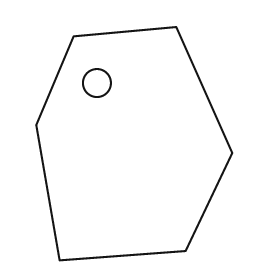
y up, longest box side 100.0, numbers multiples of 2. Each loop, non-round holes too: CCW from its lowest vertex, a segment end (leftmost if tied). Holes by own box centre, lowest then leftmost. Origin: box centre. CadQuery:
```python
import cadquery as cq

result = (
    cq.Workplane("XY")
    .moveTo(-32.0, -50.0)
    .lineTo(22.0, -46.0)
    .lineTo(42.0, -4.0)
    .lineTo(18.0, 50.0)
    .lineTo(-26.0, 46.0)
    .lineTo(-42.0, 8.0)
    .close()
    .moveTo(-16.0, 26.0)
    .circle(6.0)
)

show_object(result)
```